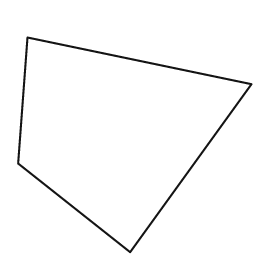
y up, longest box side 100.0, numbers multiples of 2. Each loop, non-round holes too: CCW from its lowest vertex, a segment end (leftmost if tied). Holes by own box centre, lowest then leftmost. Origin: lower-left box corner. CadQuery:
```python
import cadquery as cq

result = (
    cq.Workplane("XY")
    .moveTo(48.0, 0.0)
    .lineTo(100.0, 72.0)
    .lineTo(4.0, 92.0)
    .lineTo(0.0, 38.0)
    .close()
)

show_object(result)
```